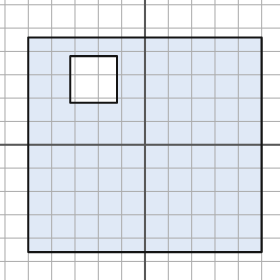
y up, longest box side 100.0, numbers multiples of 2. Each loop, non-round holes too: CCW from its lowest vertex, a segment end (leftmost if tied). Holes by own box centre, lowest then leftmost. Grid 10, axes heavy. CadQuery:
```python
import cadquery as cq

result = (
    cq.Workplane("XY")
    .moveTo(-50.0, -46.0)
    .lineTo(50.0, -46.0)
    .lineTo(50.0, 46.0)
    .lineTo(-50.0, 46.0)
    .close()
    .moveTo(-32.0, 18.0)
    .lineTo(-12.0, 18.0)
    .lineTo(-12.0, 38.0)
    .lineTo(-32.0, 38.0)
    .close()
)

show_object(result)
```